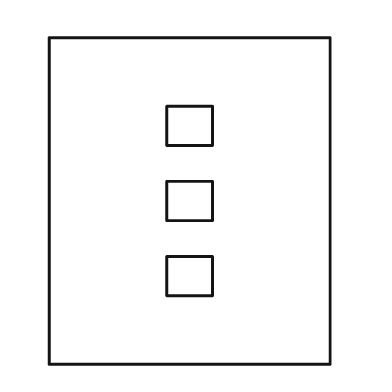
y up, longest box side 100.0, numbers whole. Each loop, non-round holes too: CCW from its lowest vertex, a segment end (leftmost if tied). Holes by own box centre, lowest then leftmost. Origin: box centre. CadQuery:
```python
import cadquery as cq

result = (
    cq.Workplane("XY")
    .moveTo(-43.0, -50.0)
    .lineTo(43.0, -50.0)
    .lineTo(43.0, 50.0)
    .lineTo(-43.0, 50.0)
    .close()
    .moveTo(-7.0, -29.0)
    .lineTo(7.0, -29.0)
    .lineTo(7.0, -17.0)
    .lineTo(-7.0, -17.0)
    .close()
    .moveTo(-7.0, -6.0)
    .lineTo(7.0, -6.0)
    .lineTo(7.0, 6.0)
    .lineTo(-7.0, 6.0)
    .close()
    .moveTo(-7.0, 17.0)
    .lineTo(7.0, 17.0)
    .lineTo(7.0, 29.0)
    .lineTo(-7.0, 29.0)
    .close()
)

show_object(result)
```